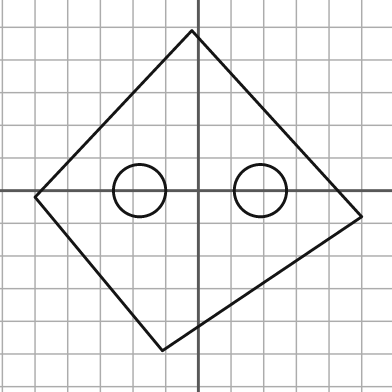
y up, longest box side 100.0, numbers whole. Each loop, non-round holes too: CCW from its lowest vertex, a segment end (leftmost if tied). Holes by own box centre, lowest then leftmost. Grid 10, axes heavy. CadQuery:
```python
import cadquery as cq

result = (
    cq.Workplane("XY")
    .moveTo(-11.0, -49.0)
    .lineTo(50.0, -8.0)
    .lineTo(-2.0, 49.0)
    .lineTo(-50.0, -2.0)
    .close()
    .moveTo(-18.0, 0.0)
    .circle(8.0)
    .moveTo(19.0, 0.0)
    .circle(8.0)
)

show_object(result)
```